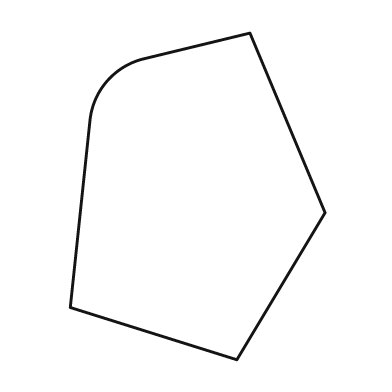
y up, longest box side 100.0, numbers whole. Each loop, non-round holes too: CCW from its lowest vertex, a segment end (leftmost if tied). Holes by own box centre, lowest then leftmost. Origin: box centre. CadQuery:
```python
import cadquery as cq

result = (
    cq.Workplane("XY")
    .moveTo(12.0, -50.0)
    .lineTo(39.0, -5.0)
    .lineTo(16.0, 50.0)
    .lineTo(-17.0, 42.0)
    .threePointArc((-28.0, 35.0), (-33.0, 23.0))
    .lineTo(-39.0, -34.0)
    .close()
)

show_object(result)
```